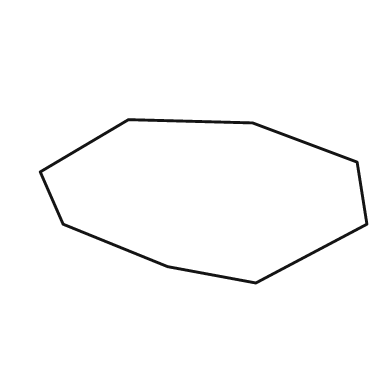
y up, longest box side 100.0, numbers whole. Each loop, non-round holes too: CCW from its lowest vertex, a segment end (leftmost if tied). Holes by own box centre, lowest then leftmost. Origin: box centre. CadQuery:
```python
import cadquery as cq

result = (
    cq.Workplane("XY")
    .moveTo(16.0, -25.0)
    .lineTo(50.0, -7.0)
    .lineTo(47.0, 12.0)
    .lineTo(15.0, 24.0)
    .lineTo(-23.0, 25.0)
    .lineTo(-50.0, 9.0)
    .lineTo(-43.0, -7.0)
    .lineTo(-11.0, -20.0)
    .close()
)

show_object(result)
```